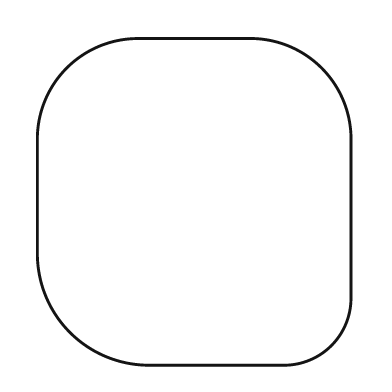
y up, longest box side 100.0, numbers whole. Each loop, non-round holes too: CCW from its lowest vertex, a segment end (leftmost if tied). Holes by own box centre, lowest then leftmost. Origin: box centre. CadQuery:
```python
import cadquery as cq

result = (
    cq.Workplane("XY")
    .moveTo(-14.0, -50.0)
    .lineTo(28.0, -50.0)
    .threePointArc((42.0, -44.0), (48.0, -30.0))
    .lineTo(48.0, 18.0)
    .threePointArc((39.0, 41.0), (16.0, 50.0))
    .lineTo(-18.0, 50.0)
    .threePointArc((-39.0, 41.0), (-48.0, 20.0))
    .lineTo(-48.0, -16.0)
    .threePointArc((-38.0, -40.0), (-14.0, -50.0))
    .close()
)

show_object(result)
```